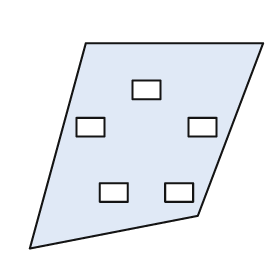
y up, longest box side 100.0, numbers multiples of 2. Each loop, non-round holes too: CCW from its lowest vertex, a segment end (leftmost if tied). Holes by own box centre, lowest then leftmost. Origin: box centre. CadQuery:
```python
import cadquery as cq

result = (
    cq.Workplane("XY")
    .moveTo(-50.0, -44.0)
    .lineTo(22.0, -30.0)
    .lineTo(50.0, 44.0)
    .lineTo(-26.0, 44.0)
    .close()
    .moveTo(-20.0, -24.0)
    .lineTo(-8.0, -24.0)
    .lineTo(-8.0, -16.0)
    .lineTo(-20.0, -16.0)
    .close()
    .moveTo(8.0, -24.0)
    .lineTo(20.0, -24.0)
    .lineTo(20.0, -16.0)
    .lineTo(8.0, -16.0)
    .close()
    .moveTo(-30.0, 4.0)
    .lineTo(-18.0, 4.0)
    .lineTo(-18.0, 12.0)
    .lineTo(-30.0, 12.0)
    .close()
    .moveTo(18.0, 4.0)
    .lineTo(30.0, 4.0)
    .lineTo(30.0, 12.0)
    .lineTo(18.0, 12.0)
    .close()
    .moveTo(-6.0, 20.0)
    .lineTo(6.0, 20.0)
    .lineTo(6.0, 28.0)
    .lineTo(-6.0, 28.0)
    .close()
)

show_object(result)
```